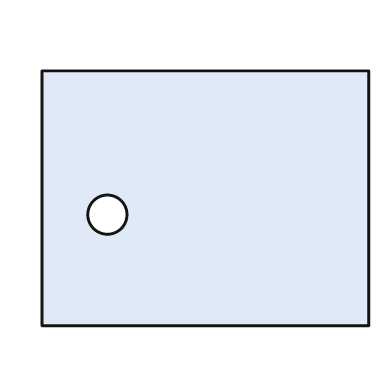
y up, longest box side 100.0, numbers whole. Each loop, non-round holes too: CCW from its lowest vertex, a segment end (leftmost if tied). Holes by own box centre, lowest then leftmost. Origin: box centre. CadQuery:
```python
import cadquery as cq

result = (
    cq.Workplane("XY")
    .moveTo(-50.0, -39.0)
    .lineTo(50.0, -39.0)
    .lineTo(50.0, 39.0)
    .lineTo(-50.0, 39.0)
    .close()
    .moveTo(-30.0, -5.0)
    .circle(6.0)
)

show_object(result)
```